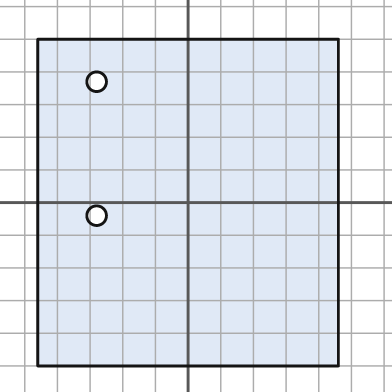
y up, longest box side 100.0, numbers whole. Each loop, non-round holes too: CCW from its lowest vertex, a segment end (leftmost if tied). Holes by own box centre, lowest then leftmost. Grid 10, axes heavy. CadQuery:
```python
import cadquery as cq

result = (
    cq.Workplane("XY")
    .moveTo(-46.0, -50.0)
    .lineTo(46.0, -50.0)
    .lineTo(46.0, 50.0)
    .lineTo(-46.0, 50.0)
    .close()
    .moveTo(-28.0, -4.0)
    .circle(3.0)
    .moveTo(-28.0, 37.0)
    .circle(3.0)
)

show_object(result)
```